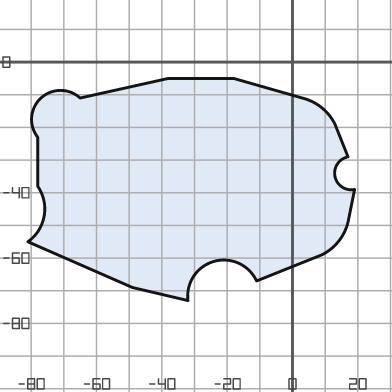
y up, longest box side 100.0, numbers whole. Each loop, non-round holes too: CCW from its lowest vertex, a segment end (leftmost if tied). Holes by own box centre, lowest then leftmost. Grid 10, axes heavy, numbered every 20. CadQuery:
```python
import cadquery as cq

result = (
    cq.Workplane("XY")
    .moveTo(-32.0, -73.0)
    .threePointArc((-24.0, -61.0), (-11.0, -67.0))
    .lineTo(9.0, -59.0)
    .threePointArc((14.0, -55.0), (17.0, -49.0))
    .lineTo(19.0, -39.0)
    .threePointArc((13.0, -35.0), (17.0, -29.0))
    .lineTo(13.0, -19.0)
    .threePointArc((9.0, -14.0), (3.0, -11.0))
    .lineTo(-18.0, -5.0)
    .lineTo(-38.0, -5.0)
    .lineTo(-65.0, -11.0)
    .threePointArc((-77.0, -11.0), (-78.0, -23.0))
    .lineTo(-78.0, -38.0)
    .threePointArc((-76.0, -47.0), (-81.0, -55.0))
    .lineTo(-49.0, -69.0)
    .close()
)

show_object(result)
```